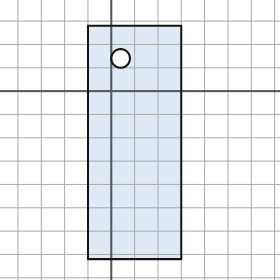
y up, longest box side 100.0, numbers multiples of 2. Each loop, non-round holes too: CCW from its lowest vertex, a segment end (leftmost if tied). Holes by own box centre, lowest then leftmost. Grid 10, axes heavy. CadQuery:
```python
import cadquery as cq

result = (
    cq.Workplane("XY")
    .moveTo(-10.0, -72.0)
    .lineTo(30.0, -72.0)
    .lineTo(30.0, 28.0)
    .lineTo(-10.0, 28.0)
    .close()
    .moveTo(4.0, 14.0)
    .circle(4.0)
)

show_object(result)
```